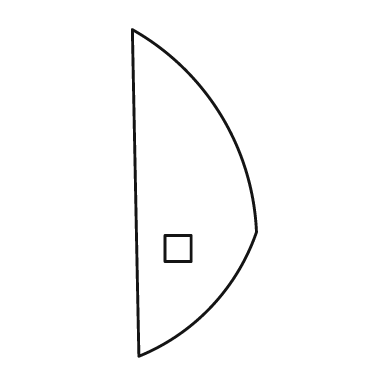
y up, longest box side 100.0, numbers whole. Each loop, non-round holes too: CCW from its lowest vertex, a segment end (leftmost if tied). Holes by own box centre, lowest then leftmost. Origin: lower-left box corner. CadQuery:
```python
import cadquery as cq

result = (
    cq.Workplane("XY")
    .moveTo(2.0, 0.0)
    .threePointArc((24.0, 15.0), (38.0, 38.0))
    .threePointArc((27.0, 74.0), (0.0, 100.0))
    .close()
    .moveTo(10.0, 29.0)
    .lineTo(18.0, 29.0)
    .lineTo(18.0, 37.0)
    .lineTo(10.0, 37.0)
    .close()
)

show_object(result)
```